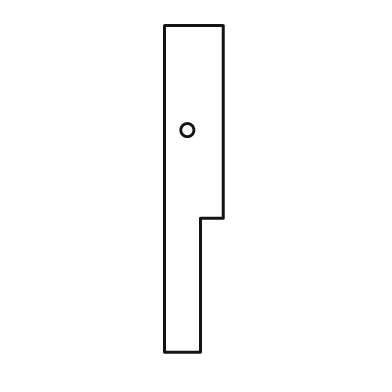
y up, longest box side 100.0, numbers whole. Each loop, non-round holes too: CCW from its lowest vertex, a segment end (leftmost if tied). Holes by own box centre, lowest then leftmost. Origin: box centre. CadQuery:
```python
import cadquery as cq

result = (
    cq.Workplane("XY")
    .moveTo(-9.0, -50.0)
    .lineTo(2.0, -50.0)
    .lineTo(2.0, -9.0)
    .lineTo(9.0, -9.0)
    .lineTo(9.0, 50.0)
    .lineTo(-9.0, 50.0)
    .close()
    .moveTo(-2.0, 18.0)
    .circle(2.0)
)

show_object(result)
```